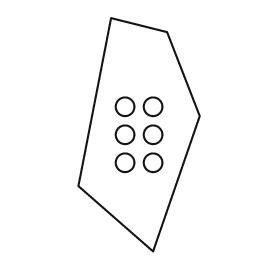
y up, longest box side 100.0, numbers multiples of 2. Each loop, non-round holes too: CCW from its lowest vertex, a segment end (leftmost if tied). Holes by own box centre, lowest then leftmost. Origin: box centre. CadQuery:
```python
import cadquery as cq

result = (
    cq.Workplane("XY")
    .moveTo(6.0, -50.0)
    .lineTo(26.0, 8.0)
    .lineTo(12.0, 44.0)
    .lineTo(-12.0, 50.0)
    .lineTo(-26.0, -22.0)
    .close()
    .moveTo(-6.0, -12.0)
    .circle(4.0)
    .moveTo(6.0, -12.0)
    .circle(4.0)
    .moveTo(-6.0, 0.0)
    .circle(4.0)
    .moveTo(6.0, 0.0)
    .circle(4.0)
    .moveTo(-6.0, 12.0)
    .circle(4.0)
    .moveTo(6.0, 12.0)
    .circle(4.0)
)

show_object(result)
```